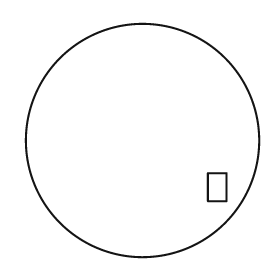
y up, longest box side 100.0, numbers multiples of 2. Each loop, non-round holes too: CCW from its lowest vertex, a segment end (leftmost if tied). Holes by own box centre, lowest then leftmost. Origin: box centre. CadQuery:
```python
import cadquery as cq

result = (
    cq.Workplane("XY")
    .moveTo(0.0, 0.0)
    .circle(50.0)
    .moveTo(28.0, -26.0)
    .lineTo(36.0, -26.0)
    .lineTo(36.0, -14.0)
    .lineTo(28.0, -14.0)
    .close()
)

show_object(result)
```